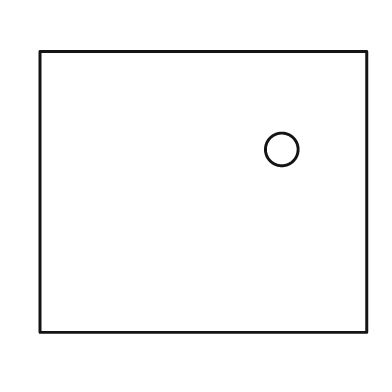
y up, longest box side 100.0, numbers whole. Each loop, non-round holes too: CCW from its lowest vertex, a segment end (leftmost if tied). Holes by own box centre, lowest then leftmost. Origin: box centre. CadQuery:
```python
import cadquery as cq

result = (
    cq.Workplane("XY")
    .moveTo(-50.0, -43.0)
    .lineTo(50.0, -43.0)
    .lineTo(50.0, 43.0)
    .lineTo(-50.0, 43.0)
    .close()
    .moveTo(24.0, 13.0)
    .circle(5.0)
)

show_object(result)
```